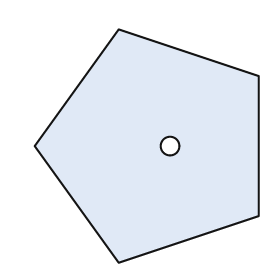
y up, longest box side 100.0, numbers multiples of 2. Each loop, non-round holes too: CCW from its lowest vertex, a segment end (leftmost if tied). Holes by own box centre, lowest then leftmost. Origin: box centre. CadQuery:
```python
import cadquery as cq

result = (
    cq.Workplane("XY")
    .moveTo(-12.0, -50.0)
    .lineTo(48.0, -30.0)
    .lineTo(48.0, 30.0)
    .lineTo(-12.0, 50.0)
    .lineTo(-48.0, 0.0)
    .close()
    .moveTo(10.0, 0.0)
    .circle(4.0)
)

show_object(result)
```